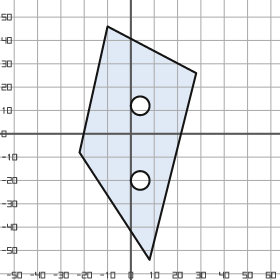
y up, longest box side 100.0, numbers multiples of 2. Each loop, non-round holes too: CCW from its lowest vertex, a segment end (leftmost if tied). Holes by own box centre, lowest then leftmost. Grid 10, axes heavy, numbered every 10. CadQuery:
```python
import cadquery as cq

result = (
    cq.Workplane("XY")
    .moveTo(8.0, -54.0)
    .lineTo(28.0, 26.0)
    .lineTo(-10.0, 46.0)
    .lineTo(-22.0, -8.0)
    .close()
    .moveTo(4.0, -20.0)
    .circle(4.0)
    .moveTo(4.0, 12.0)
    .circle(4.0)
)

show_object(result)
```